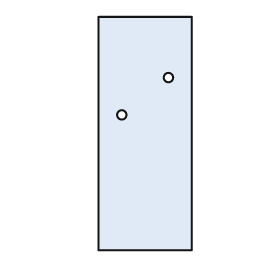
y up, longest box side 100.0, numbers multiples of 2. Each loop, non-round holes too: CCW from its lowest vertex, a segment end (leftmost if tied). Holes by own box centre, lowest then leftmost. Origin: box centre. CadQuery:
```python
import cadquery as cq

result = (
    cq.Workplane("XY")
    .moveTo(-20.0, -50.0)
    .lineTo(20.0, -50.0)
    .lineTo(20.0, 50.0)
    .lineTo(-20.0, 50.0)
    .close()
    .moveTo(-10.0, 8.0)
    .circle(2.0)
    .moveTo(10.0, 24.0)
    .circle(2.0)
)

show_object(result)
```